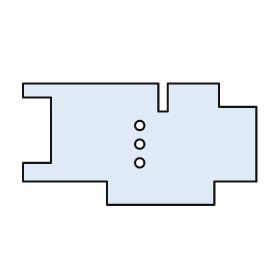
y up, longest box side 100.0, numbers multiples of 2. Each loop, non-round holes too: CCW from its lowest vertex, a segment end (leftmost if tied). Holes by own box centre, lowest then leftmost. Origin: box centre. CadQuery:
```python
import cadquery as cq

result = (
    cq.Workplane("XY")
    .moveTo(-14.0, -26.0)
    .lineTo(32.0, -26.0)
    .lineTo(32.0, -16.0)
    .lineTo(50.0, -16.0)
    .lineTo(50.0, 16.0)
    .lineTo(34.0, 16.0)
    .lineTo(34.0, 26.0)
    .lineTo(12.0, 26.0)
    .lineTo(12.0, 14.0)
    .lineTo(8.0, 14.0)
    .lineTo(8.0, 26.0)
    .lineTo(-50.0, 26.0)
    .lineTo(-50.0, 20.0)
    .lineTo(-38.0, 20.0)
    .lineTo(-38.0, -8.0)
    .lineTo(-50.0, -8.0)
    .lineTo(-50.0, -16.0)
    .lineTo(-14.0, -16.0)
    .close()
    .moveTo(0.0, -8.0)
    .circle(2.0)
    .moveTo(0.0, 0.0)
    .circle(2.0)
    .moveTo(0.0, 8.0)
    .circle(2.0)
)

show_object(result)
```